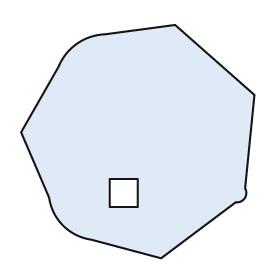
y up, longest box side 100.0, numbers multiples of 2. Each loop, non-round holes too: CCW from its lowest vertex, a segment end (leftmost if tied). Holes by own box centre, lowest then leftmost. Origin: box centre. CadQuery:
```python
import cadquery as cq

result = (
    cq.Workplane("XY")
    .moveTo(10.0, -50.0)
    .lineTo(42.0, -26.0)
    .threePointArc((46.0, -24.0), (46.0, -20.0))
    .lineTo(50.0, 20.0)
    .lineTo(16.0, 50.0)
    .lineTo(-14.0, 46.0)
    .threePointArc((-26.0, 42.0), (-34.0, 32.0))
    .lineTo(-50.0, 4.0)
    .lineTo(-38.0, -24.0)
    .threePointArc((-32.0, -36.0), (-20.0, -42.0))
    .close()
    .moveTo(-12.0, -28.0)
    .lineTo(0.0, -28.0)
    .lineTo(0.0, -16.0)
    .lineTo(-12.0, -16.0)
    .close()
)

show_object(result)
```